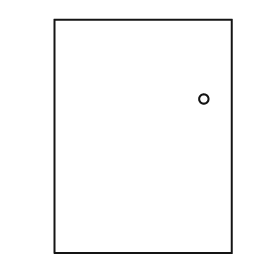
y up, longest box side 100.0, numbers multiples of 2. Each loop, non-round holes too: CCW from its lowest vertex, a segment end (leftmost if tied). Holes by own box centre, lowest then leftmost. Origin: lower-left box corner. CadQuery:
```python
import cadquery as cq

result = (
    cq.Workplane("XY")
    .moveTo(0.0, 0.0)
    .lineTo(76.0, 0.0)
    .lineTo(76.0, 100.0)
    .lineTo(0.0, 100.0)
    .close()
    .moveTo(64.0, 66.0)
    .circle(2.0)
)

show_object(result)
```